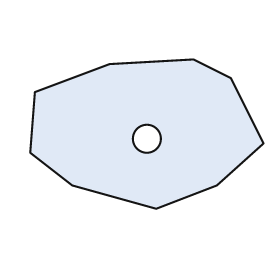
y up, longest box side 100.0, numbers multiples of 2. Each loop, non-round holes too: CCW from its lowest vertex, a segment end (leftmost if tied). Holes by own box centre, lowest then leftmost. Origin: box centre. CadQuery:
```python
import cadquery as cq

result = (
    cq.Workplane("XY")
    .moveTo(4.0, -32.0)
    .lineTo(30.0, -22.0)
    .lineTo(50.0, -4.0)
    .lineTo(36.0, 24.0)
    .lineTo(20.0, 32.0)
    .lineTo(-16.0, 30.0)
    .lineTo(-48.0, 18.0)
    .lineTo(-50.0, -8.0)
    .lineTo(-32.0, -22.0)
    .close()
    .moveTo(0.0, -2.0)
    .circle(6.0)
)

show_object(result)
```